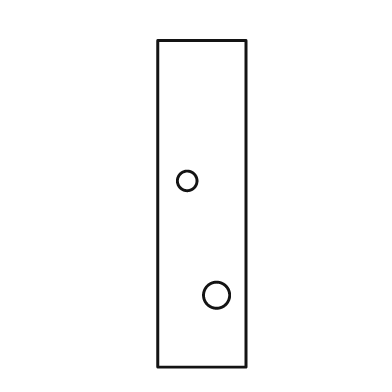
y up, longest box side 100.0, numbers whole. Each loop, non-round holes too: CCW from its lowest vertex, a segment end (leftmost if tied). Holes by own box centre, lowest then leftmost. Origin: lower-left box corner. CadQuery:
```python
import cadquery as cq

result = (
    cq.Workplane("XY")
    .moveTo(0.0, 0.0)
    .lineTo(27.0, 0.0)
    .lineTo(27.0, 100.0)
    .lineTo(0.0, 100.0)
    .close()
    .moveTo(18.0, 22.0)
    .circle(4.0)
    .moveTo(9.0, 57.0)
    .circle(3.0)
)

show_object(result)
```